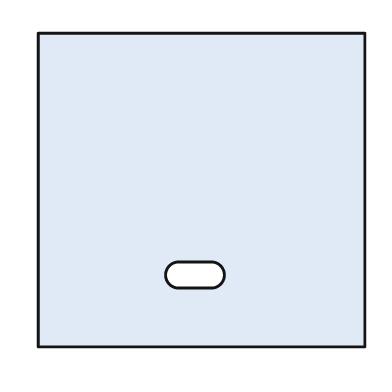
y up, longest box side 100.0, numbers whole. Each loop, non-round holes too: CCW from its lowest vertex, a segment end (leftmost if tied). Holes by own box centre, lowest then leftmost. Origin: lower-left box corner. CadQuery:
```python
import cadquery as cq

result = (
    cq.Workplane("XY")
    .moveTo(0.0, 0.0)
    .lineTo(100.0, 0.0)
    .lineTo(100.0, 96.0)
    .lineTo(0.0, 96.0)
    .close()
    .moveTo(43.0, 18.0)
    .lineTo(53.0, 18.0)
    .threePointArc((57.0, 22.0), (53.0, 26.0))
    .lineTo(43.0, 26.0)
    .threePointArc((39.0, 22.0), (43.0, 18.0))
    .close()
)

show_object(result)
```